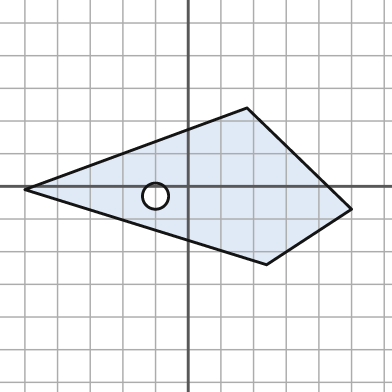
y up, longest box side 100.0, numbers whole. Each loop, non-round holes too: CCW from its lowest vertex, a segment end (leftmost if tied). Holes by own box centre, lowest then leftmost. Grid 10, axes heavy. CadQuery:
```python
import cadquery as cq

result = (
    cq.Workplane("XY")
    .moveTo(24.0, -24.0)
    .lineTo(50.0, -7.0)
    .lineTo(18.0, 24.0)
    .lineTo(-50.0, -1.0)
    .close()
    .moveTo(-10.0, -3.0)
    .circle(4.0)
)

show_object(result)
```